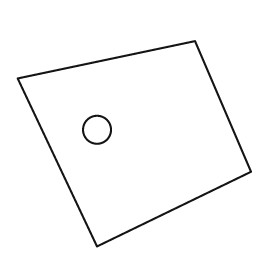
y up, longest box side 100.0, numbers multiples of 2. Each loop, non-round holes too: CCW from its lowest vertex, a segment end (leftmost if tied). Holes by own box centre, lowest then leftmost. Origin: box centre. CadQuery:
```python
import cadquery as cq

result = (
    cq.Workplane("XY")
    .moveTo(-16.0, -44.0)
    .lineTo(50.0, -12.0)
    .lineTo(26.0, 44.0)
    .lineTo(-50.0, 28.0)
    .close()
    .moveTo(-16.0, 6.0)
    .circle(6.0)
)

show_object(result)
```